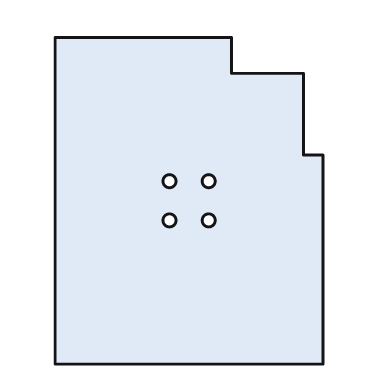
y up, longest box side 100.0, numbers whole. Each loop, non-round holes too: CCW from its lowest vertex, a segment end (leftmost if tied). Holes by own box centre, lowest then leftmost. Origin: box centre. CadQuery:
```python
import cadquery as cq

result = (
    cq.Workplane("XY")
    .moveTo(-41.0, -50.0)
    .lineTo(41.0, -50.0)
    .lineTo(41.0, 14.0)
    .lineTo(35.0, 14.0)
    .lineTo(35.0, 39.0)
    .lineTo(13.0, 39.0)
    .lineTo(13.0, 50.0)
    .lineTo(-41.0, 50.0)
    .close()
    .moveTo(-6.0, -6.0)
    .circle(2.0)
    .moveTo(6.0, -6.0)
    .circle(2.0)
    .moveTo(-6.0, 6.0)
    .circle(2.0)
    .moveTo(6.0, 6.0)
    .circle(2.0)
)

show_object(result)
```